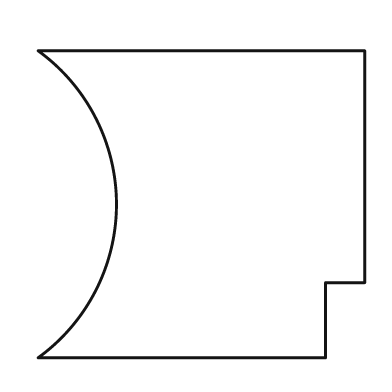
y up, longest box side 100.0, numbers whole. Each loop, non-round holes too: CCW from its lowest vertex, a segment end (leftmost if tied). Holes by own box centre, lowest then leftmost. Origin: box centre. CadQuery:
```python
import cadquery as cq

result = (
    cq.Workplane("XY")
    .moveTo(-50.0, -47.0)
    .lineTo(38.0, -47.0)
    .lineTo(38.0, -24.0)
    .lineTo(50.0, -24.0)
    .lineTo(50.0, 47.0)
    .lineTo(-50.0, 47.0)
    .threePointArc((-26.0, 0.0), (-50.0, -47.0))
    .close()
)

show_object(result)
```